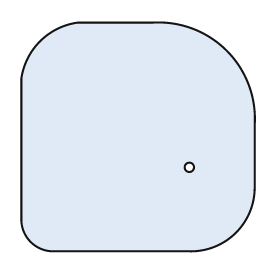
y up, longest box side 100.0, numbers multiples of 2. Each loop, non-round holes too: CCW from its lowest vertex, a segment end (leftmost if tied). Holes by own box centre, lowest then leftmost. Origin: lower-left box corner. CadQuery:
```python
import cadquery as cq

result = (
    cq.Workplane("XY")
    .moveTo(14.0, 0.0)
    .lineTo(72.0, 0.0)
    .threePointArc((92.0, 8.0), (100.0, 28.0))
    .lineTo(100.0, 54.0)
    .threePointArc((88.0, 86.0), (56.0, 98.0))
    .lineTo(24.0, 98.0)
    .threePointArc((8.0, 90.0), (0.0, 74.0))
    .lineTo(0.0, 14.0)
    .threePointArc((4.0, 4.0), (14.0, 0.0))
    .close()
    .moveTo(72.0, 36.0)
    .circle(2.0)
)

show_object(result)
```